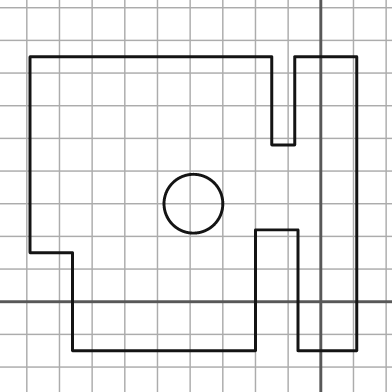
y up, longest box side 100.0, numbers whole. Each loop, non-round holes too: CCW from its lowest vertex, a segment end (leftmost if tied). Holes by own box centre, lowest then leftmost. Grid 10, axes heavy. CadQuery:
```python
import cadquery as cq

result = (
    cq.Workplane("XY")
    .moveTo(-76.0, -15.0)
    .lineTo(-20.0, -15.0)
    .lineTo(-20.0, 22.0)
    .lineTo(-7.0, 22.0)
    .lineTo(-7.0, -15.0)
    .lineTo(11.0, -15.0)
    .lineTo(11.0, 75.0)
    .lineTo(-8.0, 75.0)
    .lineTo(-8.0, 48.0)
    .lineTo(-15.0, 48.0)
    .lineTo(-15.0, 75.0)
    .lineTo(-89.0, 75.0)
    .lineTo(-89.0, 15.0)
    .lineTo(-76.0, 15.0)
    .close()
    .moveTo(-39.0, 30.0)
    .circle(9.0)
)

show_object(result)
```